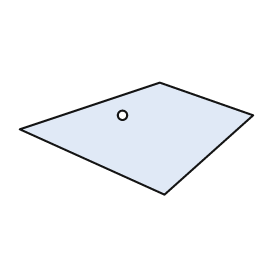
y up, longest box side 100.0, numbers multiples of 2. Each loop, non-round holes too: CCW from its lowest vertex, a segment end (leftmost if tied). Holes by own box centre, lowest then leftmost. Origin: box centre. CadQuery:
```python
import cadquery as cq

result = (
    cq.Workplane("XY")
    .moveTo(12.0, -24.0)
    .lineTo(50.0, 10.0)
    .lineTo(10.0, 24.0)
    .lineTo(-50.0, 4.0)
    .close()
    .moveTo(-6.0, 10.0)
    .circle(2.0)
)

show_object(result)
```